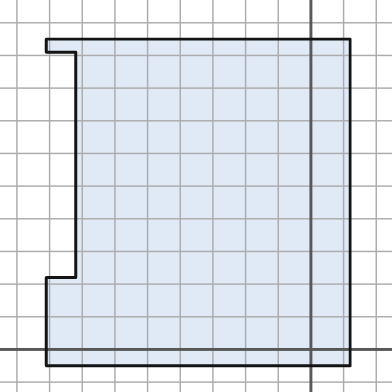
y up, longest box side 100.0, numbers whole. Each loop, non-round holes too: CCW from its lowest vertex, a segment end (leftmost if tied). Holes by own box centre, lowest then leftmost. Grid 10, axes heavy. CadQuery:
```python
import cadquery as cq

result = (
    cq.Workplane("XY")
    .moveTo(-81.0, -5.0)
    .lineTo(12.0, -5.0)
    .lineTo(12.0, 95.0)
    .lineTo(-81.0, 95.0)
    .lineTo(-81.0, 91.0)
    .lineTo(-72.0, 91.0)
    .lineTo(-72.0, 22.0)
    .lineTo(-81.0, 22.0)
    .close()
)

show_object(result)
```